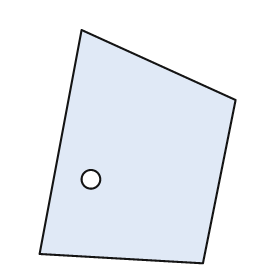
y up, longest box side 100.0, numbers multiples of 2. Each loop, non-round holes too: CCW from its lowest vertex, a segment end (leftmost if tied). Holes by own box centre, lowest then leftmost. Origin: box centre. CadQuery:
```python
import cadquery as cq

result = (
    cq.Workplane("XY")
    .moveTo(28.0, -50.0)
    .lineTo(42.0, 20.0)
    .lineTo(-24.0, 50.0)
    .lineTo(-42.0, -46.0)
    .close()
    .moveTo(-20.0, -14.0)
    .circle(4.0)
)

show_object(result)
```